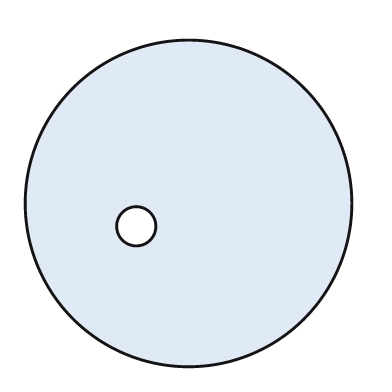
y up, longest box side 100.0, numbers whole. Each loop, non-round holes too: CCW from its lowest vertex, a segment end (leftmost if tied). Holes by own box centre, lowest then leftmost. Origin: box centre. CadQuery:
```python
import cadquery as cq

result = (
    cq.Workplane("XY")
    .moveTo(0.0, 0.0)
    .circle(50.0)
    .moveTo(-16.0, -7.0)
    .circle(6.0)
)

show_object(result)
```